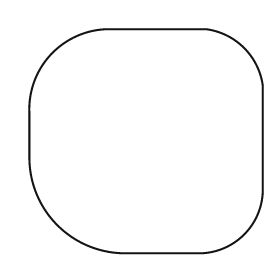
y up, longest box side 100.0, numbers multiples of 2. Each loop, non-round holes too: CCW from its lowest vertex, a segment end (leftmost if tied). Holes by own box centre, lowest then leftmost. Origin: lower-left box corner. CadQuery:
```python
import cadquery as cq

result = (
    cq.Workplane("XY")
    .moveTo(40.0, 0.0)
    .lineTo(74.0, 0.0)
    .threePointArc((92.0, 8.0), (100.0, 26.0))
    .lineTo(100.0, 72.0)
    .threePointArc((92.0, 88.0), (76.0, 96.0))
    .lineTo(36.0, 96.0)
    .threePointArc((10.0, 86.0), (0.0, 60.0))
    .lineTo(0.0, 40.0)
    .threePointArc((12.0, 12.0), (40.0, 0.0))
    .close()
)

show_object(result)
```